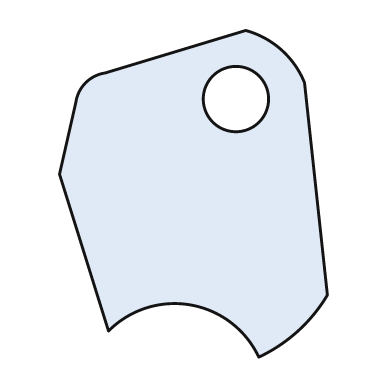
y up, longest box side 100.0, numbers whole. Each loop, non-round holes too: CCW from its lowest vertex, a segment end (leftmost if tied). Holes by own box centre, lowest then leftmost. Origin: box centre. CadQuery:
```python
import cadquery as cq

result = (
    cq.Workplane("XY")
    .moveTo(20.0, -50.0)
    .threePointArc((32.0, -42.0), (41.0, -31.0))
    .lineTo(34.0, 34.0)
    .threePointArc((27.0, 44.0), (16.0, 50.0))
    .lineTo(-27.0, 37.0)
    .threePointArc((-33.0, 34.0), (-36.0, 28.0))
    .lineTo(-41.0, 6.0)
    .lineTo(-26.0, -42.0)
    .threePointArc((-1.0, -34.0), (20.0, -50.0))
    .close()
    .moveTo(13.0, 29.0)
    .circle(10.0)
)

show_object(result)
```